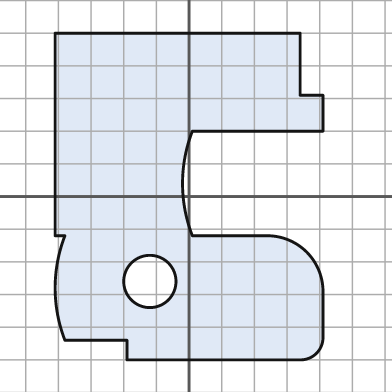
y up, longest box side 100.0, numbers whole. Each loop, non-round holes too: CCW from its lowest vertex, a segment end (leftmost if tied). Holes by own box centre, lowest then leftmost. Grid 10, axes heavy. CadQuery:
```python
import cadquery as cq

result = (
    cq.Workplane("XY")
    .moveTo(-19.0, -50.0)
    .lineTo(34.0, -50.0)
    .threePointArc((39.0, -48.0), (41.0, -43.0))
    .lineTo(41.0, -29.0)
    .threePointArc((36.0, -17.0), (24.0, -12.0))
    .lineTo(1.0, -12.0)
    .threePointArc((-2.0, 4.0), (1.0, 20.0))
    .lineTo(41.0, 20.0)
    .lineTo(41.0, 31.0)
    .lineTo(34.0, 31.0)
    .lineTo(34.0, 50.0)
    .lineTo(-41.0, 50.0)
    .lineTo(-41.0, -12.0)
    .lineTo(-38.0, -12.0)
    .threePointArc((-41.0, -28.0), (-38.0, -44.0))
    .lineTo(-19.0, -44.0)
    .close()
    .moveTo(-12.0, -26.0)
    .circle(8.0)
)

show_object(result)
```